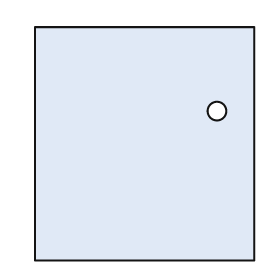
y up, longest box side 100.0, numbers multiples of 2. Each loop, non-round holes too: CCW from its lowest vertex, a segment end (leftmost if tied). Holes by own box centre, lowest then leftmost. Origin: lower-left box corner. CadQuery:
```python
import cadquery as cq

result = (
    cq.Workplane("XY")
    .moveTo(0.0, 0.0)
    .lineTo(94.0, 0.0)
    .lineTo(94.0, 100.0)
    .lineTo(0.0, 100.0)
    .close()
    .moveTo(78.0, 64.0)
    .circle(4.0)
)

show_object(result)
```